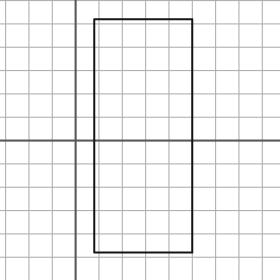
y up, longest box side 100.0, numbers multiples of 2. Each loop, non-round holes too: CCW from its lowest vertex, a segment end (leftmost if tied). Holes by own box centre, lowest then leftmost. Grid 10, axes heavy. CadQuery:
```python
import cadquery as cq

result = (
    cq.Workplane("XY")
    .moveTo(8.0, -48.0)
    .lineTo(50.0, -48.0)
    .lineTo(50.0, 52.0)
    .lineTo(8.0, 52.0)
    .close()
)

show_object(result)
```